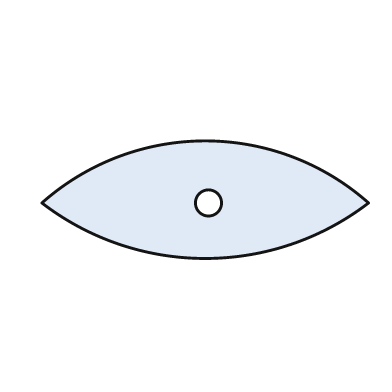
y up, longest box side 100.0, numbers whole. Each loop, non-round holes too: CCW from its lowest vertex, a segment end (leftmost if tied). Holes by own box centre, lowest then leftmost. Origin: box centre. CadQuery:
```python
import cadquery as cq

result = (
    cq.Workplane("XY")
    .moveTo(-50.0, -1.0)
    .threePointArc((0.0, -18.0), (50.0, -1.0))
    .threePointArc((0.0, 18.0), (-50.0, -1.0))
    .close()
    .moveTo(1.0, -1.0)
    .circle(4.0)
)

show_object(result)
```